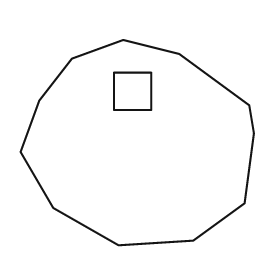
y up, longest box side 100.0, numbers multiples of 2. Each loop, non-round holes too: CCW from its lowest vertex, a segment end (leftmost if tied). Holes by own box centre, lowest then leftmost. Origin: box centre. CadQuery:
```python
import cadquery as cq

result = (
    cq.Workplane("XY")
    .moveTo(-8.0, -44.0)
    .lineTo(24.0, -42.0)
    .lineTo(46.0, -26.0)
    .lineTo(50.0, 4.0)
    .lineTo(48.0, 16.0)
    .lineTo(18.0, 38.0)
    .lineTo(-6.0, 44.0)
    .lineTo(-28.0, 36.0)
    .lineTo(-42.0, 18.0)
    .lineTo(-50.0, -4.0)
    .lineTo(-36.0, -28.0)
    .close()
    .moveTo(-10.0, 14.0)
    .lineTo(6.0, 14.0)
    .lineTo(6.0, 30.0)
    .lineTo(-10.0, 30.0)
    .close()
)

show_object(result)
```